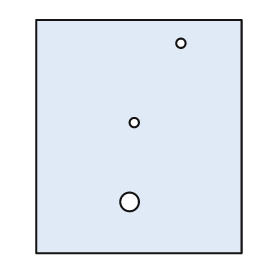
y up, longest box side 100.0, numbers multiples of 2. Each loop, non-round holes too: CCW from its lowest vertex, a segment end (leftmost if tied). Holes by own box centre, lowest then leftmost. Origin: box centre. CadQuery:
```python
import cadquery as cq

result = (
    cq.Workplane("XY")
    .moveTo(-44.0, -50.0)
    .lineTo(44.0, -50.0)
    .lineTo(44.0, 50.0)
    .lineTo(-44.0, 50.0)
    .close()
    .moveTo(-4.0, -28.0)
    .circle(4.0)
    .moveTo(-2.0, 6.0)
    .circle(2.0)
    .moveTo(18.0, 40.0)
    .circle(2.0)
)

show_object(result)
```